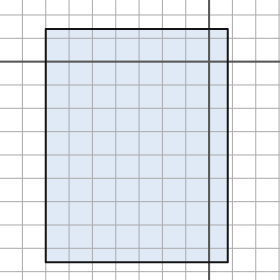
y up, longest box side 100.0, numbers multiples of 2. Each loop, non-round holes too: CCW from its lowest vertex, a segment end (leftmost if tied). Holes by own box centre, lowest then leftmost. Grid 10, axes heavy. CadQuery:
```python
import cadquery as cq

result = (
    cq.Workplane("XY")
    .moveTo(-70.0, -86.0)
    .lineTo(8.0, -86.0)
    .lineTo(8.0, 14.0)
    .lineTo(-70.0, 14.0)
    .close()
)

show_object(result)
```